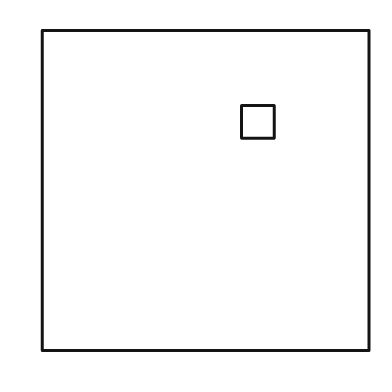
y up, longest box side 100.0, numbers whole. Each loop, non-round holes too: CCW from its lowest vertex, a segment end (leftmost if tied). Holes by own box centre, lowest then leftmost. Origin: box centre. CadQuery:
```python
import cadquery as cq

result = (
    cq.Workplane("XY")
    .moveTo(-50.0, -49.0)
    .lineTo(50.0, -49.0)
    .lineTo(50.0, 49.0)
    .lineTo(-50.0, 49.0)
    .close()
    .moveTo(11.0, 16.0)
    .lineTo(21.0, 16.0)
    .lineTo(21.0, 26.0)
    .lineTo(11.0, 26.0)
    .close()
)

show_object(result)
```